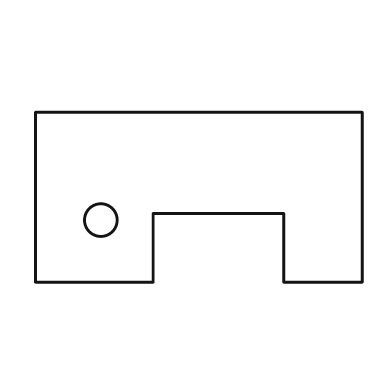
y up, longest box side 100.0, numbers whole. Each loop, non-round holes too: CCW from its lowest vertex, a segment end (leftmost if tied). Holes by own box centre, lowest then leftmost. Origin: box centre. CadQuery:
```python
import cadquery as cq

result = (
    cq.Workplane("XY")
    .moveTo(-50.0, -26.0)
    .lineTo(-14.0, -26.0)
    .lineTo(-14.0, -5.0)
    .lineTo(26.0, -5.0)
    .lineTo(26.0, -26.0)
    .lineTo(50.0, -26.0)
    .lineTo(50.0, 26.0)
    .lineTo(-50.0, 26.0)
    .close()
    .moveTo(-30.0, -7.0)
    .circle(5.0)
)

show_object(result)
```